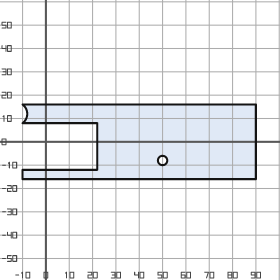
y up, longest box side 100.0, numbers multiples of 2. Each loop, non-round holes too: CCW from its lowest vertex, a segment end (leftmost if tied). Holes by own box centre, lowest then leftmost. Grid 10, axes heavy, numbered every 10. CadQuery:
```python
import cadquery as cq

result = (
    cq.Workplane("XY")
    .moveTo(-10.0, -16.0)
    .lineTo(90.0, -16.0)
    .lineTo(90.0, 16.0)
    .lineTo(-10.0, 16.0)
    .threePointArc((-8.0, 12.0), (-10.0, 8.0))
    .lineTo(22.0, 8.0)
    .lineTo(22.0, -12.0)
    .lineTo(-10.0, -12.0)
    .close()
    .moveTo(50.0, -8.0)
    .circle(2.0)
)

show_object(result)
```